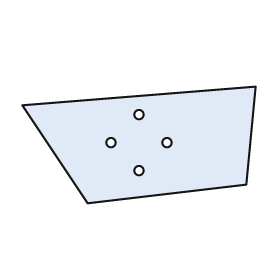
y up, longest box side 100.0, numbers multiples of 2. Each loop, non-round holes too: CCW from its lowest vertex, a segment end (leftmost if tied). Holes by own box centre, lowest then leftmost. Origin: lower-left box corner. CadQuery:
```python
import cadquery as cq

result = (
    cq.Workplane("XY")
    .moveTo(28.0, 0.0)
    .lineTo(96.0, 8.0)
    .lineTo(100.0, 50.0)
    .lineTo(0.0, 42.0)
    .close()
    .moveTo(50.0, 14.0)
    .circle(2.0)
    .moveTo(38.0, 26.0)
    .circle(2.0)
    .moveTo(62.0, 26.0)
    .circle(2.0)
    .moveTo(50.0, 38.0)
    .circle(2.0)
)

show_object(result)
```